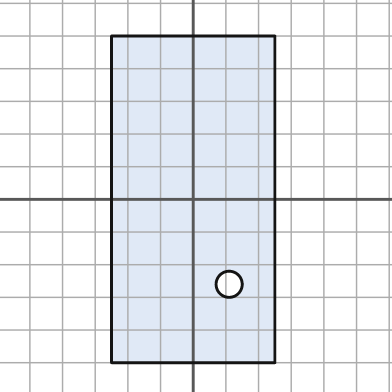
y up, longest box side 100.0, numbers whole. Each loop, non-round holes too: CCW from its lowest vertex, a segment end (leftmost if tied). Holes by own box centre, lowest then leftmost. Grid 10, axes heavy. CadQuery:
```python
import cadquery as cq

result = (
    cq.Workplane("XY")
    .moveTo(-25.0, -50.0)
    .lineTo(25.0, -50.0)
    .lineTo(25.0, 50.0)
    .lineTo(-25.0, 50.0)
    .close()
    .moveTo(11.0, -26.0)
    .circle(4.0)
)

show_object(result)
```